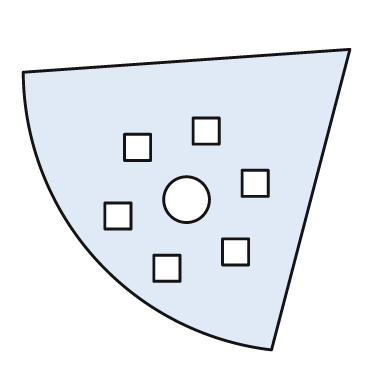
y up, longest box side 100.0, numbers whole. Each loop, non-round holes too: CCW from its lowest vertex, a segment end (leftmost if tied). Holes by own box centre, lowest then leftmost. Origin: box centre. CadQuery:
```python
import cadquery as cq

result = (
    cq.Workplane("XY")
    .moveTo(26.0, -46.0)
    .lineTo(50.0, 46.0)
    .lineTo(-50.0, 39.0)
    .threePointArc((-28.0, -18.0), (26.0, -46.0))
    .close()
    .moveTo(-10.0, -25.0)
    .lineTo(-2.0, -25.0)
    .lineTo(-2.0, -17.0)
    .lineTo(-10.0, -17.0)
    .close()
    .moveTo(11.0, -20.0)
    .lineTo(19.0, -20.0)
    .lineTo(19.0, -12.0)
    .lineTo(11.0, -12.0)
    .close()
    .moveTo(-25.0, -9.0)
    .lineTo(-17.0, -9.0)
    .lineTo(-17.0, -1.0)
    .lineTo(-25.0, -1.0)
    .close()
    .moveTo(0.0, 0.0)
    .circle(7.0)
    .moveTo(17.0, 1.0)
    .lineTo(25.0, 1.0)
    .lineTo(25.0, 9.0)
    .lineTo(17.0, 9.0)
    .close()
    .moveTo(-19.0, 12.0)
    .lineTo(-11.0, 12.0)
    .lineTo(-11.0, 20.0)
    .lineTo(-19.0, 20.0)
    .close()
    .moveTo(2.0, 17.0)
    .lineTo(10.0, 17.0)
    .lineTo(10.0, 25.0)
    .lineTo(2.0, 25.0)
    .close()
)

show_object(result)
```